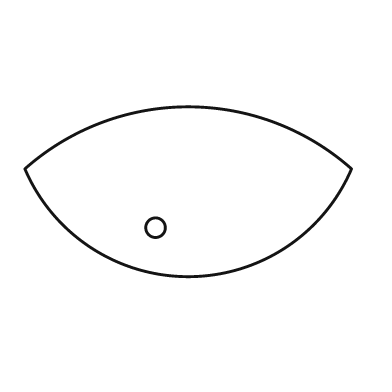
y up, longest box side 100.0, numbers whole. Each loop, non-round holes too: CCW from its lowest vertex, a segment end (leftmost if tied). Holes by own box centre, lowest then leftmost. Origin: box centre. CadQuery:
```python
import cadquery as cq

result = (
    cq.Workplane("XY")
    .moveTo(-50.0, 7.0)
    .threePointArc((0.0, -26.0), (50.0, 7.0))
    .threePointArc((0.0, 26.0), (-50.0, 7.0))
    .close()
    .moveTo(-10.0, -11.0)
    .circle(3.0)
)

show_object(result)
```